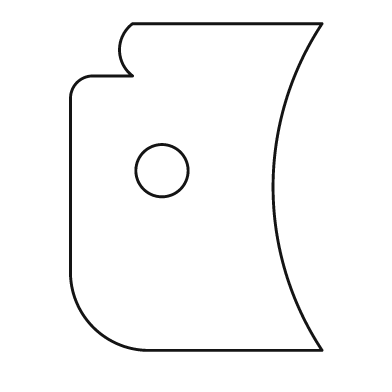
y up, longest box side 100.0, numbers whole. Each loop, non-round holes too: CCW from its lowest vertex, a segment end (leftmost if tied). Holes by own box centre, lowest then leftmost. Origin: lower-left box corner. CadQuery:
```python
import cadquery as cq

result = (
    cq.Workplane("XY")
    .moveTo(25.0, 0.0)
    .lineTo(77.0, 0.0)
    .threePointArc((62.0, 50.0), (77.0, 100.0))
    .lineTo(19.0, 100.0)
    .threePointArc((15.0, 92.0), (19.0, 84.0))
    .lineTo(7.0, 84.0)
    .threePointArc((2.0, 82.0), (0.0, 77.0))
    .lineTo(0.0, 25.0)
    .threePointArc((7.0, 7.0), (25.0, 0.0))
    .close()
    .moveTo(28.0, 55.0)
    .circle(8.0)
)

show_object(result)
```